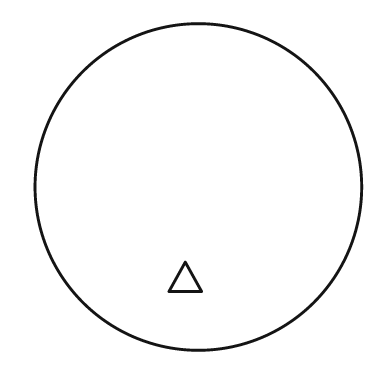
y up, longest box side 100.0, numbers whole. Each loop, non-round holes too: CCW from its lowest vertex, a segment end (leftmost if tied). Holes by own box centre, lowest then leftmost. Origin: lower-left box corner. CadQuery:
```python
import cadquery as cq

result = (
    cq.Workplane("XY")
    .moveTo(50.0, 50.0)
    .circle(50.0)
    .moveTo(41.0, 18.0)
    .lineTo(51.0, 18.0)
    .lineTo(46.0, 27.0)
    .close()
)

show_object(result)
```